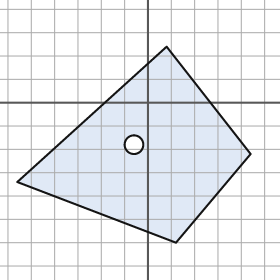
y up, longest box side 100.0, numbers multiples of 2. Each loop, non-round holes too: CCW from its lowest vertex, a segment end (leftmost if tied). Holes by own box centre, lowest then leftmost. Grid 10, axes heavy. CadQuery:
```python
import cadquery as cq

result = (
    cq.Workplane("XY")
    .moveTo(12.0, -60.0)
    .lineTo(44.0, -22.0)
    .lineTo(8.0, 24.0)
    .lineTo(-56.0, -34.0)
    .close()
    .moveTo(-6.0, -18.0)
    .circle(4.0)
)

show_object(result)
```